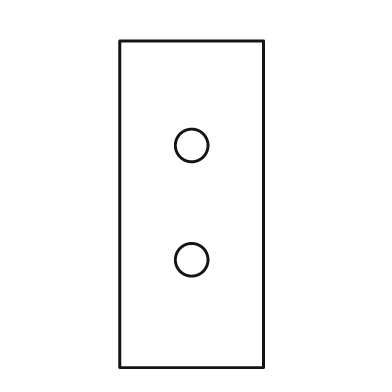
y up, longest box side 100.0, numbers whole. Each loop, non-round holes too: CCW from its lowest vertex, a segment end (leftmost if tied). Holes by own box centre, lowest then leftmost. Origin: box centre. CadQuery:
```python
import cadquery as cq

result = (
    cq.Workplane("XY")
    .moveTo(-22.0, -50.0)
    .lineTo(22.0, -50.0)
    .lineTo(22.0, 50.0)
    .lineTo(-22.0, 50.0)
    .close()
    .moveTo(0.0, -17.0)
    .circle(5.0)
    .moveTo(0.0, 18.0)
    .circle(5.0)
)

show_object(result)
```